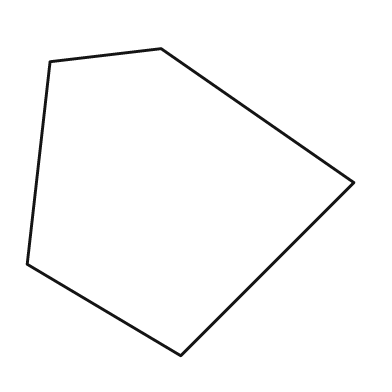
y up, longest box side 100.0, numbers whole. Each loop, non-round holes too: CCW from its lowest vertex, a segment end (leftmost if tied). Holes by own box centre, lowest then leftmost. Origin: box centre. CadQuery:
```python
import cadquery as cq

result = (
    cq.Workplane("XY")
    .moveTo(-3.0, -47.0)
    .lineTo(50.0, 6.0)
    .lineTo(-9.0, 47.0)
    .lineTo(-43.0, 43.0)
    .lineTo(-50.0, -19.0)
    .close()
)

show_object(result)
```